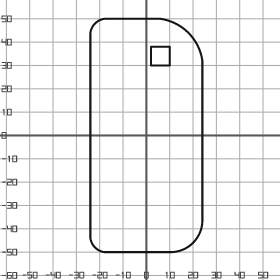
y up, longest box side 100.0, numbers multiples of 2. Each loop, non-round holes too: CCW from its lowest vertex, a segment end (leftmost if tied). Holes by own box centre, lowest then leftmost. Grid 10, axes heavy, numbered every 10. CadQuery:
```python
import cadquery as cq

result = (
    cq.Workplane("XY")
    .moveTo(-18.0, -50.0)
    .lineTo(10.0, -50.0)
    .threePointArc((20.0, -46.0), (24.0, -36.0))
    .lineTo(24.0, 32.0)
    .threePointArc((18.0, 44.0), (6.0, 50.0))
    .lineTo(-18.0, 50.0)
    .threePointArc((-22.0, 48.0), (-24.0, 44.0))
    .lineTo(-24.0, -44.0)
    .threePointArc((-22.0, -48.0), (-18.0, -50.0))
    .close()
    .moveTo(2.0, 30.0)
    .lineTo(10.0, 30.0)
    .lineTo(10.0, 38.0)
    .lineTo(2.0, 38.0)
    .close()
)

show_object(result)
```